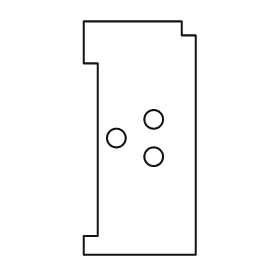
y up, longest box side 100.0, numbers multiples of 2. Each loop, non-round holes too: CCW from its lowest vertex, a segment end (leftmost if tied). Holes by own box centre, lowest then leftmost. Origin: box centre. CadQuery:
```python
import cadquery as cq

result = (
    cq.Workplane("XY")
    .moveTo(-24.0, -50.0)
    .lineTo(24.0, -50.0)
    .lineTo(24.0, 44.0)
    .lineTo(18.0, 44.0)
    .lineTo(18.0, 50.0)
    .lineTo(-24.0, 50.0)
    .lineTo(-24.0, 32.0)
    .lineTo(-18.0, 32.0)
    .lineTo(-18.0, -42.0)
    .lineTo(-24.0, -42.0)
    .close()
    .moveTo(6.0, -8.0)
    .circle(4.0)
    .moveTo(-10.0, 0.0)
    .circle(4.0)
    .moveTo(6.0, 8.0)
    .circle(4.0)
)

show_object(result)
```